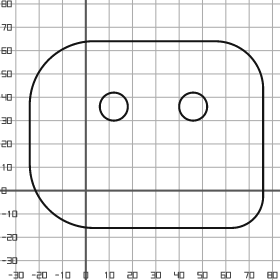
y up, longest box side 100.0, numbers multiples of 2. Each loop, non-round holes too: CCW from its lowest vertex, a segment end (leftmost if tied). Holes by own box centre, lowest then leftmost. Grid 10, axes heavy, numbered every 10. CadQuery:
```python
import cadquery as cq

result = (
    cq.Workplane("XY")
    .moveTo(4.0, -16.0)
    .lineTo(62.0, -16.0)
    .threePointArc((72.0, -12.0), (76.0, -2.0))
    .lineTo(76.0, 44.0)
    .threePointArc((70.0, 58.0), (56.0, 64.0))
    .lineTo(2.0, 64.0)
    .threePointArc((-16.0, 56.0), (-24.0, 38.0))
    .lineTo(-24.0, 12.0)
    .threePointArc((-16.0, -8.0), (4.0, -16.0))
    .close()
    .moveTo(12.0, 36.0)
    .circle(6.0)
    .moveTo(46.0, 36.0)
    .circle(6.0)
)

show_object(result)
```